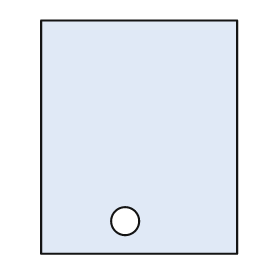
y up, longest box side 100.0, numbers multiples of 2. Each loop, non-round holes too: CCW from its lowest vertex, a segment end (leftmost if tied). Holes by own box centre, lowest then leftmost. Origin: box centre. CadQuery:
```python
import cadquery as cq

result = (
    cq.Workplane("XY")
    .moveTo(-42.0, -50.0)
    .lineTo(42.0, -50.0)
    .lineTo(42.0, 50.0)
    .lineTo(-42.0, 50.0)
    .close()
    .moveTo(-6.0, -36.0)
    .circle(6.0)
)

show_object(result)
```